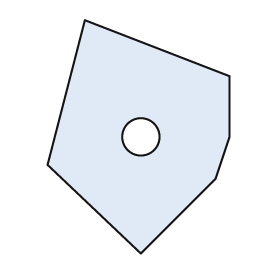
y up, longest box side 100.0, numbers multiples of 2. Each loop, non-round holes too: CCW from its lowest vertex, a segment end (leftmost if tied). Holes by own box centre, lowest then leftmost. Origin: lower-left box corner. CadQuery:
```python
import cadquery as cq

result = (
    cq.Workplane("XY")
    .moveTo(40.0, 0.0)
    .lineTo(72.0, 32.0)
    .lineTo(78.0, 50.0)
    .lineTo(78.0, 76.0)
    .lineTo(16.0, 100.0)
    .lineTo(0.0, 38.0)
    .close()
    .moveTo(40.0, 50.0)
    .circle(8.0)
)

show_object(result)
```